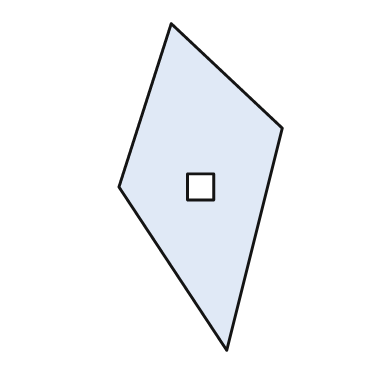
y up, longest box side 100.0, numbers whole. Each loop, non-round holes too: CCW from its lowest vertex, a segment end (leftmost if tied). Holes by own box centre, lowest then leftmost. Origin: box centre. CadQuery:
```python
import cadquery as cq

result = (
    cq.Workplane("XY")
    .moveTo(8.0, -50.0)
    .lineTo(25.0, 18.0)
    .lineTo(-9.0, 50.0)
    .lineTo(-25.0, 0.0)
    .close()
    .moveTo(-4.0, -4.0)
    .lineTo(4.0, -4.0)
    .lineTo(4.0, 4.0)
    .lineTo(-4.0, 4.0)
    .close()
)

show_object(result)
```